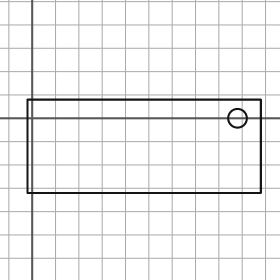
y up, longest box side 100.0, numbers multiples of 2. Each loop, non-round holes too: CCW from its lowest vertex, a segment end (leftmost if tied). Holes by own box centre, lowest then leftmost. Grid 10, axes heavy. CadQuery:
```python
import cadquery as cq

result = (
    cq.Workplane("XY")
    .moveTo(-2.0, -32.0)
    .lineTo(98.0, -32.0)
    .lineTo(98.0, 8.0)
    .lineTo(-2.0, 8.0)
    .close()
    .moveTo(88.0, 0.0)
    .circle(4.0)
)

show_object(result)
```